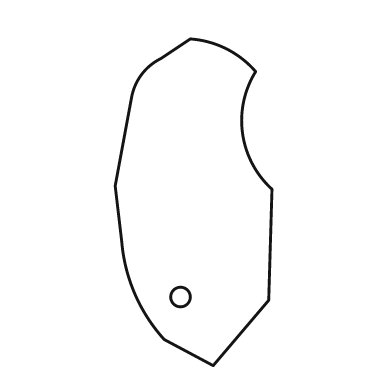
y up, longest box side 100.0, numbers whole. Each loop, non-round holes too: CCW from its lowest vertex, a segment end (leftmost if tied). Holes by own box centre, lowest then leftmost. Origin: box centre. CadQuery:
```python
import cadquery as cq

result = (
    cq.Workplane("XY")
    .moveTo(6.0, -50.0)
    .lineTo(23.0, -30.0)
    .lineTo(24.0, 4.0)
    .threePointArc((15.0, 21.0), (19.0, 40.0))
    .threePointArc((10.0, 47.0), (-1.0, 50.0))
    .lineTo(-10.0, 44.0)
    .threePointArc((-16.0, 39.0), (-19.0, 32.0))
    .lineTo(-24.0, 5.0)
    .lineTo(-22.0, -12.0)
    .threePointArc((-18.0, -28.0), (-9.0, -42.0))
    .close()
    .moveTo(-4.0, -29.0)
    .circle(3.0)
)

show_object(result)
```